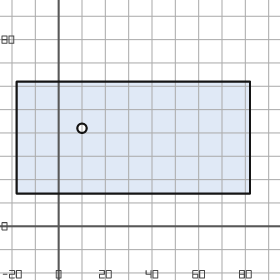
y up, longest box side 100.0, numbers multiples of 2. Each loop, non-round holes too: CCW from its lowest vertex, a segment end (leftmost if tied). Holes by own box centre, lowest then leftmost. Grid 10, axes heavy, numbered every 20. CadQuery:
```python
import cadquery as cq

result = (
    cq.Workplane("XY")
    .moveTo(-18.0, 14.0)
    .lineTo(82.0, 14.0)
    .lineTo(82.0, 62.0)
    .lineTo(-18.0, 62.0)
    .close()
    .moveTo(10.0, 42.0)
    .circle(2.0)
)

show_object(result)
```